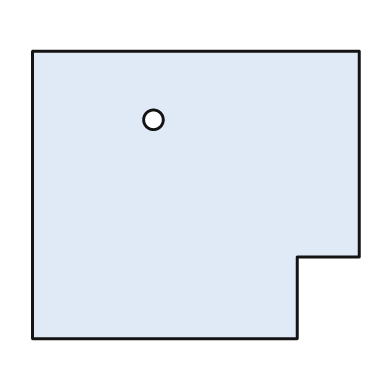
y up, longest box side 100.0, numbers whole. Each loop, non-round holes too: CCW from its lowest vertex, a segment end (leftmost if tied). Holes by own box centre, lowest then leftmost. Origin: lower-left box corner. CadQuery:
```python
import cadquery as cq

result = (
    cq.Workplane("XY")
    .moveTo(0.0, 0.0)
    .lineTo(81.0, 0.0)
    .lineTo(81.0, 25.0)
    .lineTo(100.0, 25.0)
    .lineTo(100.0, 88.0)
    .lineTo(0.0, 88.0)
    .close()
    .moveTo(37.0, 67.0)
    .circle(3.0)
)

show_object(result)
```